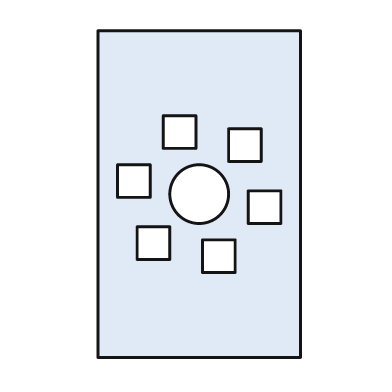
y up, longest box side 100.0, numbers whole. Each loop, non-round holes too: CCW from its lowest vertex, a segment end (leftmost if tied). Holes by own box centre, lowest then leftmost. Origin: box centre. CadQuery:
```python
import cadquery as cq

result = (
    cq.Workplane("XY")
    .moveTo(-31.0, -50.0)
    .lineTo(31.0, -50.0)
    .lineTo(31.0, 50.0)
    .lineTo(-31.0, 50.0)
    .close()
    .moveTo(1.0, -24.0)
    .lineTo(11.0, -24.0)
    .lineTo(11.0, -14.0)
    .lineTo(1.0, -14.0)
    .close()
    .moveTo(-19.0, -20.0)
    .lineTo(-9.0, -20.0)
    .lineTo(-9.0, -10.0)
    .lineTo(-19.0, -10.0)
    .close()
    .moveTo(15.0, -9.0)
    .lineTo(25.0, -9.0)
    .lineTo(25.0, 1.0)
    .lineTo(15.0, 1.0)
    .close()
    .moveTo(0.0, 0.0)
    .circle(9.0)
    .moveTo(-25.0, -1.0)
    .lineTo(-15.0, -1.0)
    .lineTo(-15.0, 9.0)
    .lineTo(-25.0, 9.0)
    .close()
    .moveTo(9.0, 10.0)
    .lineTo(19.0, 10.0)
    .lineTo(19.0, 20.0)
    .lineTo(9.0, 20.0)
    .close()
    .moveTo(-11.0, 14.0)
    .lineTo(-1.0, 14.0)
    .lineTo(-1.0, 24.0)
    .lineTo(-11.0, 24.0)
    .close()
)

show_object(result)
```